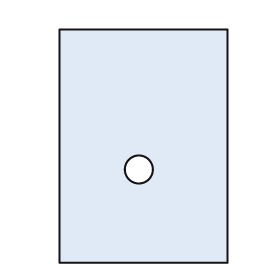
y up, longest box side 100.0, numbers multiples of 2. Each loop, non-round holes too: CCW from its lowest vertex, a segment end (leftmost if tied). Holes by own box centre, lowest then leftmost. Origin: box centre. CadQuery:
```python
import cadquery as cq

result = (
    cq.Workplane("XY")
    .moveTo(-36.0, -50.0)
    .lineTo(36.0, -50.0)
    .lineTo(36.0, 50.0)
    .lineTo(-36.0, 50.0)
    .close()
    .moveTo(-2.0, -10.0)
    .circle(6.0)
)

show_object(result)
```